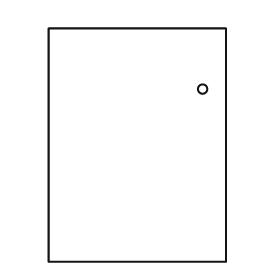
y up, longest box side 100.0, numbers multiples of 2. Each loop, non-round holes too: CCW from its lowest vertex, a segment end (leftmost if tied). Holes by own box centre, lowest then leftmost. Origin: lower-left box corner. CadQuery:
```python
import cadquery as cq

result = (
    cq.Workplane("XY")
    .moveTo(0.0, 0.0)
    .lineTo(76.0, 0.0)
    .lineTo(76.0, 100.0)
    .lineTo(0.0, 100.0)
    .close()
    .moveTo(66.0, 74.0)
    .circle(2.0)
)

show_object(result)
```